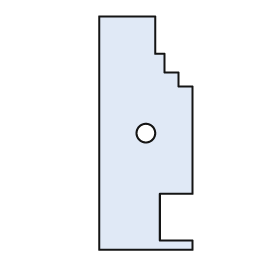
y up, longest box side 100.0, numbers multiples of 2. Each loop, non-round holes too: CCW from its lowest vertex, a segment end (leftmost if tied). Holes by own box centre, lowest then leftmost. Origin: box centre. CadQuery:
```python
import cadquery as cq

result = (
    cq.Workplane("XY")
    .moveTo(-20.0, -50.0)
    .lineTo(20.0, -50.0)
    .lineTo(20.0, -46.0)
    .lineTo(6.0, -46.0)
    .lineTo(6.0, -26.0)
    .lineTo(20.0, -26.0)
    .lineTo(20.0, 20.0)
    .lineTo(14.0, 20.0)
    .lineTo(14.0, 26.0)
    .lineTo(8.0, 26.0)
    .lineTo(8.0, 34.0)
    .lineTo(4.0, 34.0)
    .lineTo(4.0, 50.0)
    .lineTo(-20.0, 50.0)
    .close()
    .moveTo(0.0, 0.0)
    .circle(4.0)
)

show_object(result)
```